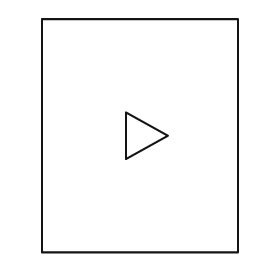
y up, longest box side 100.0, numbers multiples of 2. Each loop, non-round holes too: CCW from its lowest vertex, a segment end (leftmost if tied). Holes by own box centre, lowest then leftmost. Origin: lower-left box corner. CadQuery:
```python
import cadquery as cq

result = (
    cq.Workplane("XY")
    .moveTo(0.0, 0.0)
    .lineTo(84.0, 0.0)
    .lineTo(84.0, 100.0)
    .lineTo(0.0, 100.0)
    .close()
    .moveTo(36.0, 40.0)
    .lineTo(54.0, 50.0)
    .lineTo(36.0, 60.0)
    .close()
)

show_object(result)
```